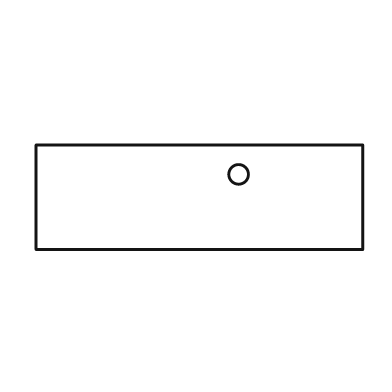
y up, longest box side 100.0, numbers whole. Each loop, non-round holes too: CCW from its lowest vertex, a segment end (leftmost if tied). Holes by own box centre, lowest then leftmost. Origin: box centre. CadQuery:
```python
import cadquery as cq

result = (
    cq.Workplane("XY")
    .moveTo(-50.0, -16.0)
    .lineTo(50.0, -16.0)
    .lineTo(50.0, 16.0)
    .lineTo(-50.0, 16.0)
    .close()
    .moveTo(12.0, 7.0)
    .circle(3.0)
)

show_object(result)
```